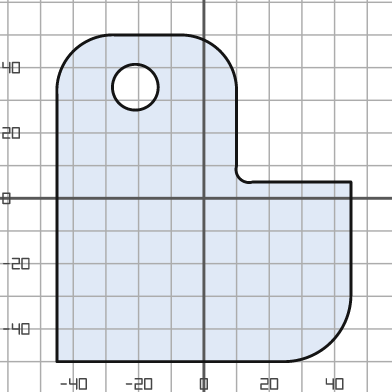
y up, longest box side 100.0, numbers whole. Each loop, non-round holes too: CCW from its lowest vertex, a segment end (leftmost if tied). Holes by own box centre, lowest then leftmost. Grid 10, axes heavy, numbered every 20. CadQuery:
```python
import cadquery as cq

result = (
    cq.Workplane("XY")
    .moveTo(-45.0, -50.0)
    .lineTo(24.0, -50.0)
    .threePointArc((39.0, -44.0), (45.0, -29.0))
    .lineTo(45.0, 5.0)
    .lineTo(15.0, 5.0)
    .threePointArc((11.0, 6.0), (10.0, 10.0))
    .lineTo(10.0, 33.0)
    .threePointArc((5.0, 45.0), (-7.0, 50.0))
    .lineTo(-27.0, 50.0)
    .threePointArc((-40.0, 45.0), (-45.0, 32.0))
    .close()
    .moveTo(-21.0, 34.0)
    .circle(7.0)
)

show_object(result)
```